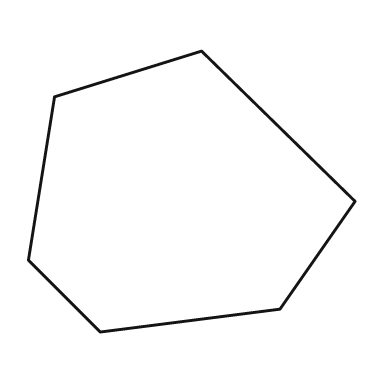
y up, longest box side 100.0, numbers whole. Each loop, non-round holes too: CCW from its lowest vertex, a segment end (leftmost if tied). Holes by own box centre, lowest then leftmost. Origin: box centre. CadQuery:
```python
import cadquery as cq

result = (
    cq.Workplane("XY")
    .moveTo(-28.0, -43.0)
    .lineTo(27.0, -36.0)
    .lineTo(50.0, -3.0)
    .lineTo(3.0, 43.0)
    .lineTo(-42.0, 29.0)
    .lineTo(-50.0, -21.0)
    .close()
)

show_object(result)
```